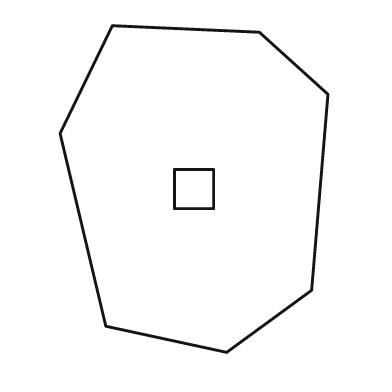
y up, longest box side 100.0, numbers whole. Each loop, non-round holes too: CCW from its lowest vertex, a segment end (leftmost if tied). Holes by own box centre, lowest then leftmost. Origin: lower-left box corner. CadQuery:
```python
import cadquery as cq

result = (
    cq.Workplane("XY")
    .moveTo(51.0, 0.0)
    .lineTo(77.0, 19.0)
    .lineTo(82.0, 79.0)
    .lineTo(61.0, 98.0)
    .lineTo(16.0, 100.0)
    .lineTo(0.0, 67.0)
    .lineTo(14.0, 8.0)
    .close()
    .moveTo(35.0, 44.0)
    .lineTo(47.0, 44.0)
    .lineTo(47.0, 56.0)
    .lineTo(35.0, 56.0)
    .close()
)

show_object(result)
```